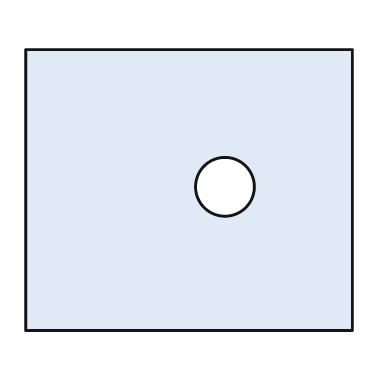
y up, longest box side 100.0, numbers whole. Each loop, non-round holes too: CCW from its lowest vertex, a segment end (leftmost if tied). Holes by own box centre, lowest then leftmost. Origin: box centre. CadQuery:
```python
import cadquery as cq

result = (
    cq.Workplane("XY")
    .moveTo(-50.0, -43.0)
    .lineTo(50.0, -43.0)
    .lineTo(50.0, 43.0)
    .lineTo(-50.0, 43.0)
    .close()
    .moveTo(11.0, 1.0)
    .circle(9.0)
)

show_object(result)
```